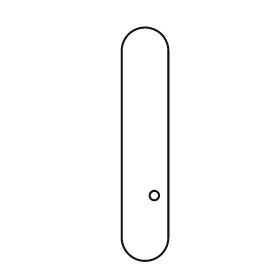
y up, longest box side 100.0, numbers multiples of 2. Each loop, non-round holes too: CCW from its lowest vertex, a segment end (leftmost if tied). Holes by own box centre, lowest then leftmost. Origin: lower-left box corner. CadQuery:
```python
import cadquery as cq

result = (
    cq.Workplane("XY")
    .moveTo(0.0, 10.0)
    .threePointArc((10.0, 0.0), (20.0, 10.0))
    .lineTo(20.0, 90.0)
    .threePointArc((10.0, 100.0), (0.0, 90.0))
    .close()
    .moveTo(14.0, 28.0)
    .circle(2.0)
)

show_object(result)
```